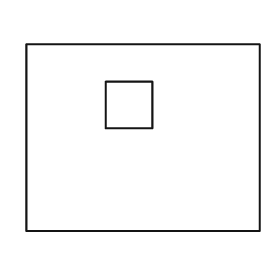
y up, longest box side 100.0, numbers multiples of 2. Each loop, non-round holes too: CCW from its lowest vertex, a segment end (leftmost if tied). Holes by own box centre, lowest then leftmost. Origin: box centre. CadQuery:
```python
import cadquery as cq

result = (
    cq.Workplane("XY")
    .moveTo(-50.0, -40.0)
    .lineTo(50.0, -40.0)
    .lineTo(50.0, 40.0)
    .lineTo(-50.0, 40.0)
    .close()
    .moveTo(-16.0, 4.0)
    .lineTo(4.0, 4.0)
    .lineTo(4.0, 24.0)
    .lineTo(-16.0, 24.0)
    .close()
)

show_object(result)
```